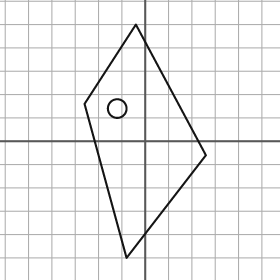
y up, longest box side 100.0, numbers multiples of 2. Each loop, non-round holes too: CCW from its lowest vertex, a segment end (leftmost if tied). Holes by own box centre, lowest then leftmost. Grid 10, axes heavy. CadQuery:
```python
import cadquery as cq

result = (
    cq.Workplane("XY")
    .moveTo(-8.0, -50.0)
    .lineTo(26.0, -6.0)
    .lineTo(-4.0, 50.0)
    .lineTo(-26.0, 16.0)
    .close()
    .moveTo(-12.0, 14.0)
    .circle(4.0)
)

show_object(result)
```